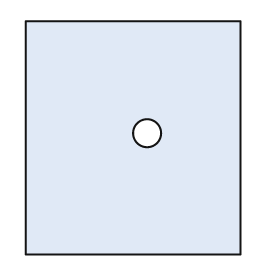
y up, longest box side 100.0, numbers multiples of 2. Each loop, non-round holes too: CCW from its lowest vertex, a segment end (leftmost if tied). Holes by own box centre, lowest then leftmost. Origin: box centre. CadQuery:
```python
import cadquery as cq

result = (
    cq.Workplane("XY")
    .moveTo(-46.0, -50.0)
    .lineTo(46.0, -50.0)
    .lineTo(46.0, 50.0)
    .lineTo(-46.0, 50.0)
    .close()
    .moveTo(6.0, 2.0)
    .circle(6.0)
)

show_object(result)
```